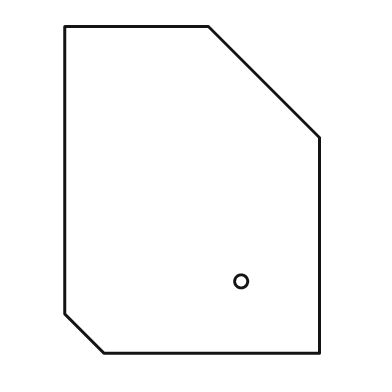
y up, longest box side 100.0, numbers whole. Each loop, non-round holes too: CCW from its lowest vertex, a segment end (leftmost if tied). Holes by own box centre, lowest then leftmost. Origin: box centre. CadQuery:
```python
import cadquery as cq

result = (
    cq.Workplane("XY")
    .moveTo(-27.0, -50.0)
    .lineTo(39.0, -50.0)
    .lineTo(39.0, 16.0)
    .lineTo(5.0, 50.0)
    .lineTo(-39.0, 50.0)
    .lineTo(-39.0, -38.0)
    .close()
    .moveTo(15.0, -28.0)
    .circle(2.0)
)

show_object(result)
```